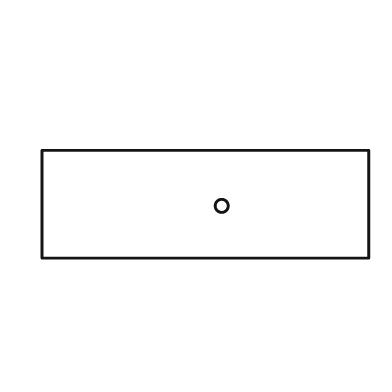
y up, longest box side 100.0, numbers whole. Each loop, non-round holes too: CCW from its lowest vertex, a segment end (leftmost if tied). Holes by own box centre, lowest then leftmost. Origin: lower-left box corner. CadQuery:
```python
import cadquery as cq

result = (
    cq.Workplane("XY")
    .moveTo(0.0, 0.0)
    .lineTo(100.0, 0.0)
    .lineTo(100.0, 33.0)
    .lineTo(0.0, 33.0)
    .close()
    .moveTo(55.0, 16.0)
    .circle(2.0)
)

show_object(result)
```